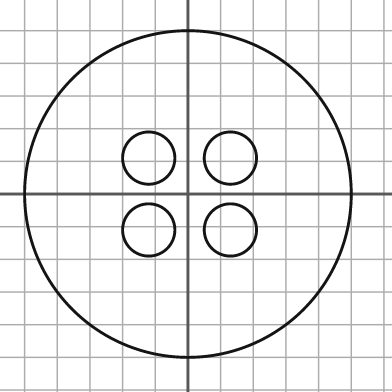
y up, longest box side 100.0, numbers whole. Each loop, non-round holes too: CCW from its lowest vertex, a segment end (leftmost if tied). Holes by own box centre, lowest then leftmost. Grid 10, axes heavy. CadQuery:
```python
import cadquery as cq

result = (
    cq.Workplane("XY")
    .moveTo(0.0, 0.0)
    .circle(50.0)
    .moveTo(-12.0, -11.0)
    .circle(8.0)
    .moveTo(13.0, -11.0)
    .circle(8.0)
    .moveTo(-12.0, 11.0)
    .circle(8.0)
    .moveTo(13.0, 11.0)
    .circle(8.0)
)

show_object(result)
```